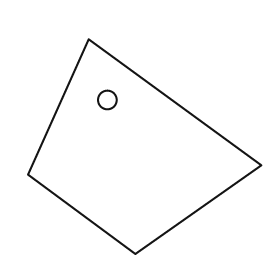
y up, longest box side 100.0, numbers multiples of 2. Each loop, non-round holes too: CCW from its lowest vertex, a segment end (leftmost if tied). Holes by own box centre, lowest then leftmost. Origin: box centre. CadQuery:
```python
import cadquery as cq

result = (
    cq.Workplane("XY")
    .moveTo(-4.0, -46.0)
    .lineTo(50.0, -8.0)
    .lineTo(-24.0, 46.0)
    .lineTo(-50.0, -12.0)
    .close()
    .moveTo(-16.0, 20.0)
    .circle(4.0)
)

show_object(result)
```